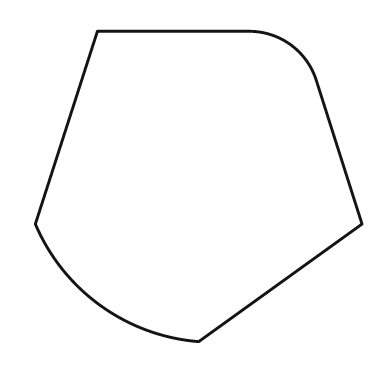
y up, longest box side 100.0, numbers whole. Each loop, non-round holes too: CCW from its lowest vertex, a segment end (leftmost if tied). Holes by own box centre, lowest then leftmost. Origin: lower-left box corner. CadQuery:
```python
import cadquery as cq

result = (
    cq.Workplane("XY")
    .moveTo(50.0, 0.0)
    .lineTo(100.0, 36.0)
    .lineTo(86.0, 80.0)
    .threePointArc((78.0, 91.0), (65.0, 95.0))
    .lineTo(19.0, 95.0)
    .lineTo(0.0, 36.0)
    .threePointArc((20.0, 11.0), (50.0, 0.0))
    .close()
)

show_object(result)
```